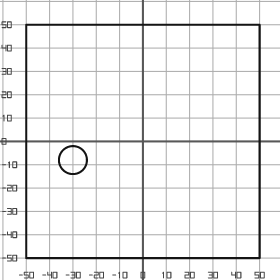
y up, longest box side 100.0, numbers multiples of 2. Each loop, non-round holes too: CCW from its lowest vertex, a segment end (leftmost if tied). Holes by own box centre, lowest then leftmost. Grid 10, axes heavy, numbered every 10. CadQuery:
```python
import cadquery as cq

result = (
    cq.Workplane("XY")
    .moveTo(-50.0, -50.0)
    .lineTo(50.0, -50.0)
    .lineTo(50.0, 50.0)
    .lineTo(-50.0, 50.0)
    .close()
    .moveTo(-30.0, -8.0)
    .circle(6.0)
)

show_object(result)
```